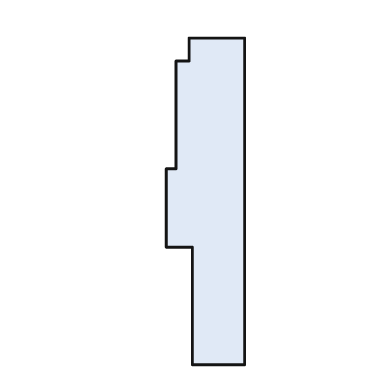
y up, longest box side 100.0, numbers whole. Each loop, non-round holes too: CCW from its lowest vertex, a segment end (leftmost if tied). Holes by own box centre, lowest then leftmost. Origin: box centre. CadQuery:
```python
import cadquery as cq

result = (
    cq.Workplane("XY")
    .moveTo(-4.0, -50.0)
    .lineTo(12.0, -50.0)
    .lineTo(12.0, 50.0)
    .lineTo(-5.0, 50.0)
    .lineTo(-5.0, 43.0)
    .lineTo(-9.0, 43.0)
    .lineTo(-9.0, 10.0)
    .lineTo(-12.0, 10.0)
    .lineTo(-12.0, -14.0)
    .lineTo(-4.0, -14.0)
    .close()
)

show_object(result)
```